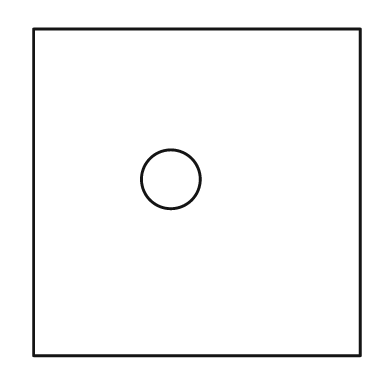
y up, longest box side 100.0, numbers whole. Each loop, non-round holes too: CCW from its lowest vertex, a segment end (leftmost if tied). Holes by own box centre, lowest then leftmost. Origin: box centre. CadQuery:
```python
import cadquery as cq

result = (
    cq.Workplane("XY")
    .moveTo(-50.0, -50.0)
    .lineTo(50.0, -50.0)
    .lineTo(50.0, 50.0)
    .lineTo(-50.0, 50.0)
    .close()
    .moveTo(-8.0, 4.0)
    .circle(9.0)
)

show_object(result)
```